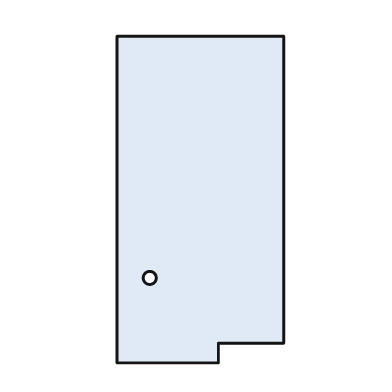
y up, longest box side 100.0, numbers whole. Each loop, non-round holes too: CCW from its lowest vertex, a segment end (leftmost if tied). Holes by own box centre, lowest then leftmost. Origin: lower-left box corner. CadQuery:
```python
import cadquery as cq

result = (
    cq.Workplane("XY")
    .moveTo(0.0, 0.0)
    .lineTo(31.0, 0.0)
    .lineTo(31.0, 6.0)
    .lineTo(51.0, 6.0)
    .lineTo(51.0, 100.0)
    .lineTo(0.0, 100.0)
    .close()
    .moveTo(10.0, 26.0)
    .circle(2.0)
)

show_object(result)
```